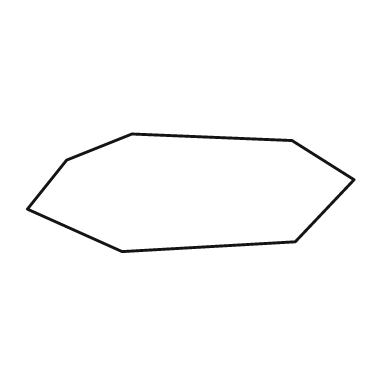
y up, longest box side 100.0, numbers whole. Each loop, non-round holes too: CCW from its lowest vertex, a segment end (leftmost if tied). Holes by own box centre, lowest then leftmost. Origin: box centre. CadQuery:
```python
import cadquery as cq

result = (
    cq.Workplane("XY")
    .moveTo(-21.0, -18.0)
    .lineTo(32.0, -15.0)
    .lineTo(50.0, 4.0)
    .lineTo(31.0, 16.0)
    .lineTo(-18.0, 18.0)
    .lineTo(-38.0, 10.0)
    .lineTo(-50.0, -5.0)
    .close()
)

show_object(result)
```